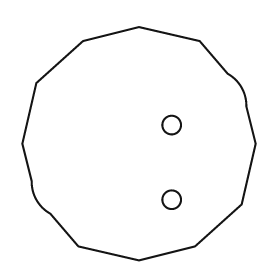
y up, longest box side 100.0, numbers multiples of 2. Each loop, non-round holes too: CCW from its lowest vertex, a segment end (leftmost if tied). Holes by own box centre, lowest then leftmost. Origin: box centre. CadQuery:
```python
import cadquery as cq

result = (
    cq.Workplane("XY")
    .moveTo(0.0, -50.0)
    .lineTo(24.0, -44.0)
    .lineTo(44.0, -26.0)
    .lineTo(50.0, 0.0)
    .lineTo(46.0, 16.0)
    .threePointArc((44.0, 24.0), (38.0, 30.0))
    .lineTo(26.0, 44.0)
    .lineTo(0.0, 50.0)
    .lineTo(-24.0, 44.0)
    .lineTo(-44.0, 26.0)
    .lineTo(-50.0, 0.0)
    .lineTo(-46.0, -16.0)
    .threePointArc((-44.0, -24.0), (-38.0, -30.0))
    .lineTo(-26.0, -44.0)
    .close()
    .moveTo(14.0, -24.0)
    .circle(4.0)
    .moveTo(14.0, 8.0)
    .circle(4.0)
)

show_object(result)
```